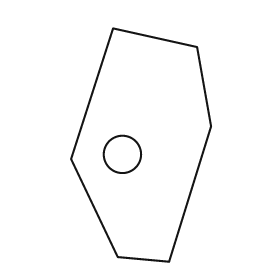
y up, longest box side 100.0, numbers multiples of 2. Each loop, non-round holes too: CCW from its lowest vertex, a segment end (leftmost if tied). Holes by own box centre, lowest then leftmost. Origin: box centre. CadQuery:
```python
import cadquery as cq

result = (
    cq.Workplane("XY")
    .moveTo(12.0, -50.0)
    .lineTo(30.0, 8.0)
    .lineTo(24.0, 42.0)
    .lineTo(-12.0, 50.0)
    .lineTo(-30.0, -6.0)
    .lineTo(-10.0, -48.0)
    .close()
    .moveTo(-8.0, -4.0)
    .circle(8.0)
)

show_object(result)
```